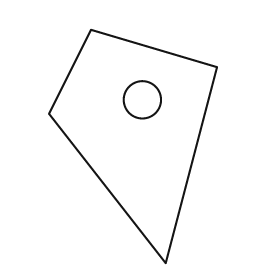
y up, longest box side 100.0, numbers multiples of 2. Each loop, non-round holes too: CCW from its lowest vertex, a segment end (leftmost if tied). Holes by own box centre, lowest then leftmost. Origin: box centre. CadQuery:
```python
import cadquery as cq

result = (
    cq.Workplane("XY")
    .moveTo(14.0, -50.0)
    .lineTo(36.0, 34.0)
    .lineTo(-18.0, 50.0)
    .lineTo(-36.0, 14.0)
    .close()
    .moveTo(4.0, 20.0)
    .circle(8.0)
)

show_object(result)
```